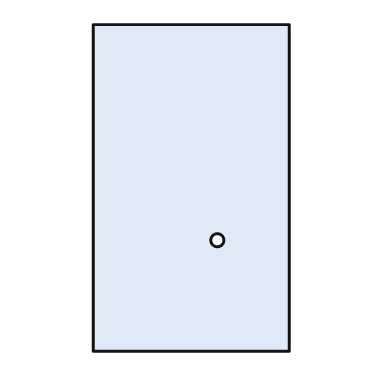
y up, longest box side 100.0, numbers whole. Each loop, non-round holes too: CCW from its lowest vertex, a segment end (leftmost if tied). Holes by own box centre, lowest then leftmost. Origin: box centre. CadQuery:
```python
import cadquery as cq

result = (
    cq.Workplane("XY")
    .moveTo(-30.0, -50.0)
    .lineTo(30.0, -50.0)
    .lineTo(30.0, 50.0)
    .lineTo(-30.0, 50.0)
    .close()
    .moveTo(8.0, -16.0)
    .circle(2.0)
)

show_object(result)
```